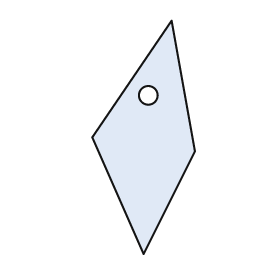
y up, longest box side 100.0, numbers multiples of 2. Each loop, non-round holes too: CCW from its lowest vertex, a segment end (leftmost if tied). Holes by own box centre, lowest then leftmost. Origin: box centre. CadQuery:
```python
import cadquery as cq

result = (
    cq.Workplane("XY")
    .moveTo(0.0, -50.0)
    .lineTo(22.0, -6.0)
    .lineTo(12.0, 50.0)
    .lineTo(-22.0, 0.0)
    .close()
    .moveTo(2.0, 18.0)
    .circle(4.0)
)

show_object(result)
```